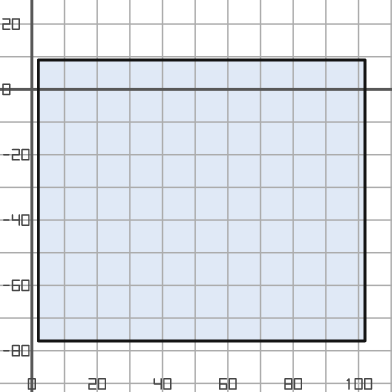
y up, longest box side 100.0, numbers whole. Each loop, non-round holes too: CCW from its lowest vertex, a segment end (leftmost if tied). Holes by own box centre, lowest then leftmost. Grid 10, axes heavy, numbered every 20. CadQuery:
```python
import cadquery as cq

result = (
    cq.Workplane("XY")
    .moveTo(2.0, -77.0)
    .lineTo(102.0, -77.0)
    .lineTo(102.0, 9.0)
    .lineTo(2.0, 9.0)
    .close()
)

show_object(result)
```